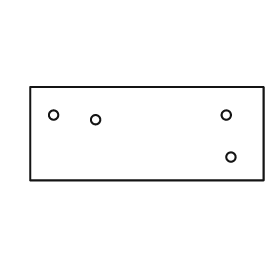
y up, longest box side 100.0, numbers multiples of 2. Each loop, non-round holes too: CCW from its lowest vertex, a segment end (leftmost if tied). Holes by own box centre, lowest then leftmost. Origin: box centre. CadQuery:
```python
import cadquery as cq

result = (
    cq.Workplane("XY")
    .moveTo(-50.0, -20.0)
    .lineTo(50.0, -20.0)
    .lineTo(50.0, 20.0)
    .lineTo(-50.0, 20.0)
    .close()
    .moveTo(36.0, -10.0)
    .circle(2.0)
    .moveTo(-22.0, 6.0)
    .circle(2.0)
    .moveTo(-40.0, 8.0)
    .circle(2.0)
    .moveTo(34.0, 8.0)
    .circle(2.0)
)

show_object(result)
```